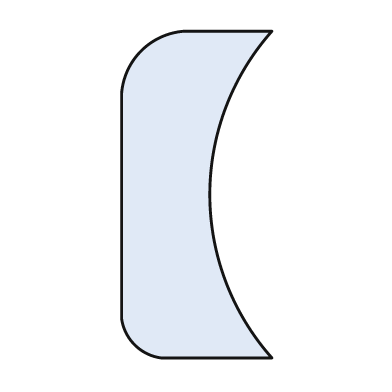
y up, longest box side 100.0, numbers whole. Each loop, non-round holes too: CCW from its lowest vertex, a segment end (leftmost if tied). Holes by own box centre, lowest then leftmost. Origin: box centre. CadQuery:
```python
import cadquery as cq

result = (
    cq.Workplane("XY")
    .moveTo(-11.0, -50.0)
    .lineTo(23.0, -50.0)
    .threePointArc((4.0, 0.0), (23.0, 50.0))
    .lineTo(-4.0, 50.0)
    .threePointArc((-17.0, 44.0), (-23.0, 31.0))
    .lineTo(-23.0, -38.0)
    .threePointArc((-19.0, -46.0), (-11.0, -50.0))
    .close()
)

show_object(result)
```